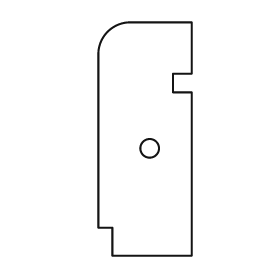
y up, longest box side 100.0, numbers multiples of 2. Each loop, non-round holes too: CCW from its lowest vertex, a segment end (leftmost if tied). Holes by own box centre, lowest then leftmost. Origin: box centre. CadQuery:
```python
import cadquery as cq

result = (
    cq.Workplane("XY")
    .moveTo(-14.0, -50.0)
    .lineTo(20.0, -50.0)
    .lineTo(20.0, 20.0)
    .lineTo(12.0, 20.0)
    .lineTo(12.0, 28.0)
    .lineTo(20.0, 28.0)
    .lineTo(20.0, 50.0)
    .lineTo(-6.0, 50.0)
    .threePointArc((-16.0, 46.0), (-20.0, 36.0))
    .lineTo(-20.0, -38.0)
    .lineTo(-14.0, -38.0)
    .close()
    .moveTo(2.0, -4.0)
    .circle(4.0)
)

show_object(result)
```